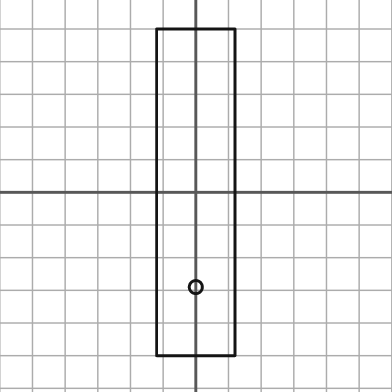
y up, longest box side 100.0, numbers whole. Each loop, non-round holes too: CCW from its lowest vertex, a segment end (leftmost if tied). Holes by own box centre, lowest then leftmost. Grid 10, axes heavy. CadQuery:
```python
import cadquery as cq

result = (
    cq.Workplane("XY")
    .moveTo(-12.0, -50.0)
    .lineTo(12.0, -50.0)
    .lineTo(12.0, 50.0)
    .lineTo(-12.0, 50.0)
    .close()
    .moveTo(0.0, -29.0)
    .circle(2.0)
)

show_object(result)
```